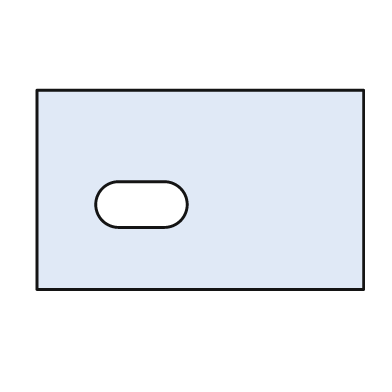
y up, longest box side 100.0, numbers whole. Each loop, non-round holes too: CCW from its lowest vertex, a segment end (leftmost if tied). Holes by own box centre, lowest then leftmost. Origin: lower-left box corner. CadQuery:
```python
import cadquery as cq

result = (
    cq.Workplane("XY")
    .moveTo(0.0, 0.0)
    .lineTo(100.0, 0.0)
    .lineTo(100.0, 61.0)
    .lineTo(0.0, 61.0)
    .close()
    .moveTo(25.0, 19.0)
    .lineTo(39.0, 19.0)
    .threePointArc((46.0, 26.0), (39.0, 33.0))
    .lineTo(25.0, 33.0)
    .threePointArc((18.0, 26.0), (25.0, 19.0))
    .close()
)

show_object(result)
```